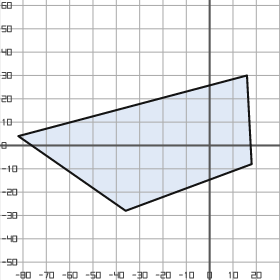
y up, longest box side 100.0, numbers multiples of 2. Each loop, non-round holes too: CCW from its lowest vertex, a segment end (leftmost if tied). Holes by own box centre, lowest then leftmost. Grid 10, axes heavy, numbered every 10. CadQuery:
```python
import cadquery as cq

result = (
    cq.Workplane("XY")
    .moveTo(-36.0, -28.0)
    .lineTo(18.0, -8.0)
    .lineTo(16.0, 30.0)
    .lineTo(-82.0, 4.0)
    .close()
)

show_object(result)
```